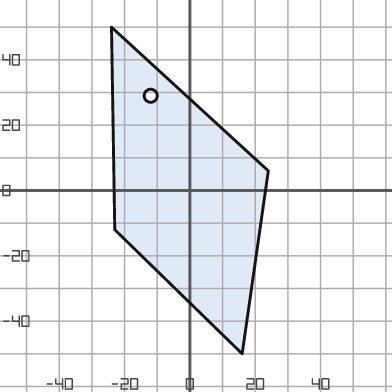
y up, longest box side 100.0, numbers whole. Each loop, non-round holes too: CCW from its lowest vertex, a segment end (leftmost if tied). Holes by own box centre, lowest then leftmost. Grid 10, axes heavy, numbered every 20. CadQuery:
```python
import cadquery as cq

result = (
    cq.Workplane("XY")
    .moveTo(16.0, -50.0)
    .lineTo(24.0, 6.0)
    .lineTo(-24.0, 50.0)
    .lineTo(-23.0, -12.0)
    .close()
    .moveTo(-12.0, 29.0)
    .circle(2.0)
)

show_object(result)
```